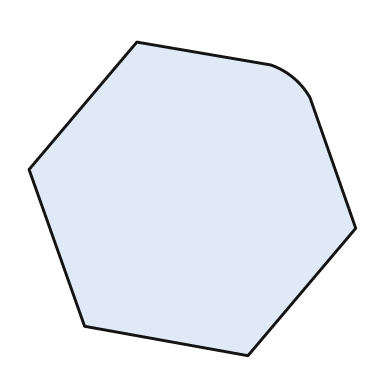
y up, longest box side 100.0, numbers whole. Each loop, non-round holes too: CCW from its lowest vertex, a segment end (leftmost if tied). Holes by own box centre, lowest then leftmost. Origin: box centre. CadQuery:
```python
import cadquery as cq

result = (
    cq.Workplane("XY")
    .moveTo(17.0, -48.0)
    .lineTo(50.0, -9.0)
    .lineTo(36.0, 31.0)
    .threePointArc((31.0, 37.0), (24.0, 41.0))
    .lineTo(-17.0, 48.0)
    .lineTo(-50.0, 9.0)
    .lineTo(-33.0, -39.0)
    .close()
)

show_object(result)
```